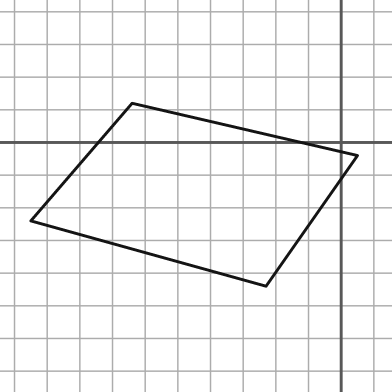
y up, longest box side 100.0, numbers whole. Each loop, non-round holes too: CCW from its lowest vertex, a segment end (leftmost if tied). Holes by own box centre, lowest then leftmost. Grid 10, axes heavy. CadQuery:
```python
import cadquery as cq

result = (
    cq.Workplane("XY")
    .moveTo(-23.0, -44.0)
    .lineTo(5.0, -4.0)
    .lineTo(-64.0, 12.0)
    .lineTo(-95.0, -24.0)
    .close()
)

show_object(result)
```